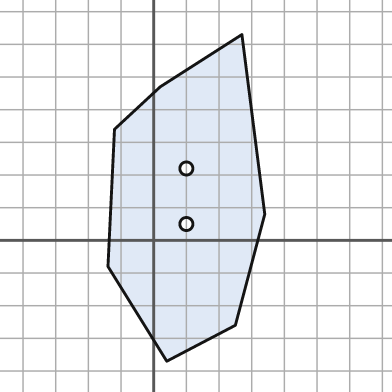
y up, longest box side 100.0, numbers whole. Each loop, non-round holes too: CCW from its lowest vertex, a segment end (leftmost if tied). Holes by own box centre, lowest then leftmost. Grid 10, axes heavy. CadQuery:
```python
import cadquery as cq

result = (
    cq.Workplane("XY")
    .moveTo(4.0, -37.0)
    .lineTo(25.0, -26.0)
    .lineTo(34.0, 8.0)
    .lineTo(27.0, 63.0)
    .lineTo(2.0, 47.0)
    .lineTo(-12.0, 34.0)
    .lineTo(-14.0, -8.0)
    .close()
    .moveTo(10.0, 5.0)
    .circle(2.0)
    .moveTo(10.0, 22.0)
    .circle(2.0)
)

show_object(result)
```